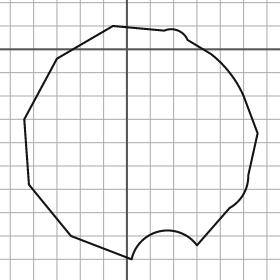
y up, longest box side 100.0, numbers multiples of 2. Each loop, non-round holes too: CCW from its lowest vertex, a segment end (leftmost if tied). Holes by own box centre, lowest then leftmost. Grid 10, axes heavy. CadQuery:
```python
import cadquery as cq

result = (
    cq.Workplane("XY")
    .moveTo(2.0, -90.0)
    .threePointArc((14.0, -78.0), (30.0, -84.0))
    .lineTo(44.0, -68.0)
    .threePointArc((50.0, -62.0), (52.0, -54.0))
    .lineTo(56.0, -36.0)
    .lineTo(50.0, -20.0)
    .threePointArc((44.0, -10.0), (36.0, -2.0))
    .lineTo(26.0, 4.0)
    .threePointArc((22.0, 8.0), (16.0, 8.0))
    .lineTo(-6.0, 10.0)
    .lineTo(-30.0, -4.0)
    .lineTo(-44.0, -30.0)
    .lineTo(-42.0, -58.0)
    .lineTo(-24.0, -80.0)
    .close()
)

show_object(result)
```